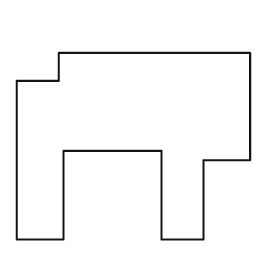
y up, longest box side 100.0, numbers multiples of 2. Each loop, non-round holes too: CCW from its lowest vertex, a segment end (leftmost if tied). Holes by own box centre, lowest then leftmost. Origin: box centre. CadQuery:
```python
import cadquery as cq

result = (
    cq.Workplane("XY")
    .moveTo(-50.0, -40.0)
    .lineTo(-30.0, -40.0)
    .lineTo(-30.0, -2.0)
    .lineTo(12.0, -2.0)
    .lineTo(12.0, -40.0)
    .lineTo(30.0, -40.0)
    .lineTo(30.0, -6.0)
    .lineTo(50.0, -6.0)
    .lineTo(50.0, 40.0)
    .lineTo(-32.0, 40.0)
    .lineTo(-32.0, 28.0)
    .lineTo(-50.0, 28.0)
    .close()
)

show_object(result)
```